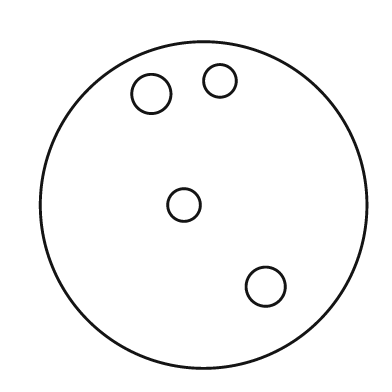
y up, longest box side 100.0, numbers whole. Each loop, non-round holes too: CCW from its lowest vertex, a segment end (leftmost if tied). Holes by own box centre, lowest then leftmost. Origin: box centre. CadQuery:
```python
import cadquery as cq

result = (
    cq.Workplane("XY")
    .moveTo(0.0, 0.0)
    .circle(50.0)
    .moveTo(19.0, -25.0)
    .circle(6.0)
    .moveTo(-6.0, 0.0)
    .circle(5.0)
    .moveTo(-16.0, 34.0)
    .circle(6.0)
    .moveTo(5.0, 38.0)
    .circle(5.0)
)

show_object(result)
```